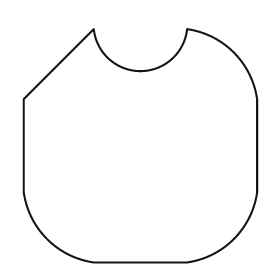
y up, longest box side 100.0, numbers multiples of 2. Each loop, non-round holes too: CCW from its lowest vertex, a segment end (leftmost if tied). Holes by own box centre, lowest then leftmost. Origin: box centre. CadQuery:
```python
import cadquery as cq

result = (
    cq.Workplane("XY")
    .moveTo(-20.0, -50.0)
    .lineTo(20.0, -50.0)
    .threePointArc((40.0, -40.0), (50.0, -20.0))
    .lineTo(50.0, 20.0)
    .threePointArc((40.0, 40.0), (20.0, 50.0))
    .threePointArc((0.0, 32.0), (-20.0, 50.0))
    .lineTo(-50.0, 20.0)
    .lineTo(-50.0, -20.0)
    .threePointArc((-40.0, -40.0), (-20.0, -50.0))
    .close()
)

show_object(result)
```